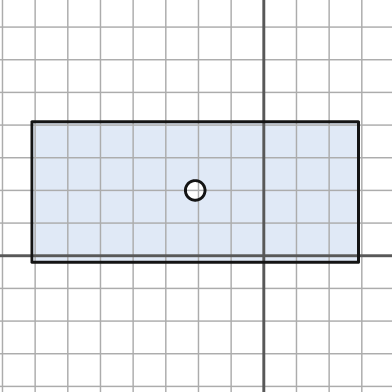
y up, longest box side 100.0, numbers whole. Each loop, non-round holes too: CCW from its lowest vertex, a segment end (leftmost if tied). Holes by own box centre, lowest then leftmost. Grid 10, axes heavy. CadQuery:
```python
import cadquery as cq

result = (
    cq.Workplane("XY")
    .moveTo(-71.0, -2.0)
    .lineTo(29.0, -2.0)
    .lineTo(29.0, 41.0)
    .lineTo(-71.0, 41.0)
    .close()
    .moveTo(-21.0, 20.0)
    .circle(3.0)
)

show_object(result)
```